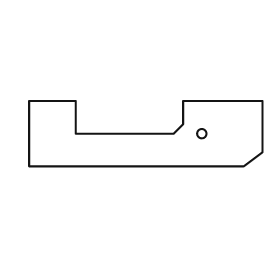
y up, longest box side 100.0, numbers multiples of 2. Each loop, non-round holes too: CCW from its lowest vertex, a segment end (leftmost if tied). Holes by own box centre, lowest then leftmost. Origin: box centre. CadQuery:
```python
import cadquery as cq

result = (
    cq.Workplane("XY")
    .moveTo(-50.0, -14.0)
    .lineTo(42.0, -14.0)
    .lineTo(50.0, -8.0)
    .lineTo(50.0, 14.0)
    .lineTo(16.0, 14.0)
    .lineTo(16.0, 4.0)
    .lineTo(12.0, 0.0)
    .lineTo(-30.0, 0.0)
    .lineTo(-30.0, 14.0)
    .lineTo(-50.0, 14.0)
    .close()
    .moveTo(24.0, 0.0)
    .circle(2.0)
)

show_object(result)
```